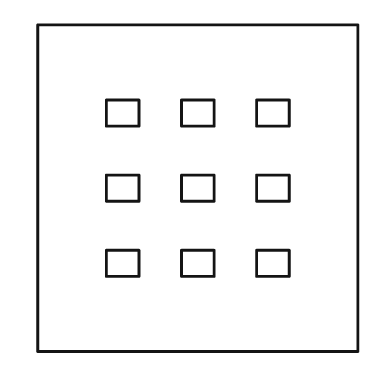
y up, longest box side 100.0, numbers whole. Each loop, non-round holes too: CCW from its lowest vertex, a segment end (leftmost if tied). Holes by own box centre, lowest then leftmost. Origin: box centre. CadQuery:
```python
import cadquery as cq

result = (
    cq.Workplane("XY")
    .moveTo(-49.0, -50.0)
    .lineTo(49.0, -50.0)
    .lineTo(49.0, 50.0)
    .lineTo(-49.0, 50.0)
    .close()
    .moveTo(-28.0, -27.0)
    .lineTo(-18.0, -27.0)
    .lineTo(-18.0, -19.0)
    .lineTo(-28.0, -19.0)
    .close()
    .moveTo(-5.0, -27.0)
    .lineTo(5.0, -27.0)
    .lineTo(5.0, -19.0)
    .lineTo(-5.0, -19.0)
    .close()
    .moveTo(18.0, -27.0)
    .lineTo(28.0, -27.0)
    .lineTo(28.0, -19.0)
    .lineTo(18.0, -19.0)
    .close()
    .moveTo(-28.0, -4.0)
    .lineTo(-18.0, -4.0)
    .lineTo(-18.0, 4.0)
    .lineTo(-28.0, 4.0)
    .close()
    .moveTo(-5.0, -4.0)
    .lineTo(5.0, -4.0)
    .lineTo(5.0, 4.0)
    .lineTo(-5.0, 4.0)
    .close()
    .moveTo(18.0, -4.0)
    .lineTo(28.0, -4.0)
    .lineTo(28.0, 4.0)
    .lineTo(18.0, 4.0)
    .close()
    .moveTo(-28.0, 19.0)
    .lineTo(-18.0, 19.0)
    .lineTo(-18.0, 27.0)
    .lineTo(-28.0, 27.0)
    .close()
    .moveTo(-5.0, 19.0)
    .lineTo(5.0, 19.0)
    .lineTo(5.0, 27.0)
    .lineTo(-5.0, 27.0)
    .close()
    .moveTo(18.0, 19.0)
    .lineTo(28.0, 19.0)
    .lineTo(28.0, 27.0)
    .lineTo(18.0, 27.0)
    .close()
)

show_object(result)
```